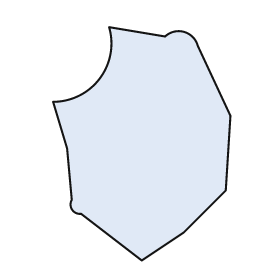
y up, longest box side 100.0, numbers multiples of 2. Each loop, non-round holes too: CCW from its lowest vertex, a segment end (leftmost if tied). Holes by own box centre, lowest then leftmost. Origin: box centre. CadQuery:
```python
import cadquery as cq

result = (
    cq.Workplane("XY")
    .moveTo(0.0, -50.0)
    .lineTo(18.0, -38.0)
    .lineTo(36.0, -20.0)
    .lineTo(38.0, 12.0)
    .lineTo(24.0, 42.0)
    .threePointArc((18.0, 48.0), (10.0, 46.0))
    .lineTo(-14.0, 50.0)
    .threePointArc((-18.0, 28.0), (-38.0, 18.0))
    .lineTo(-32.0, -2.0)
    .lineTo(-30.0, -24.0)
    .threePointArc((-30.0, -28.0), (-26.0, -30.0))
    .close()
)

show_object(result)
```